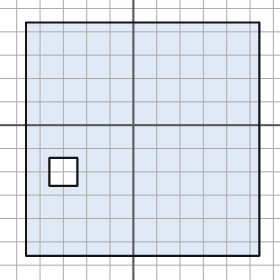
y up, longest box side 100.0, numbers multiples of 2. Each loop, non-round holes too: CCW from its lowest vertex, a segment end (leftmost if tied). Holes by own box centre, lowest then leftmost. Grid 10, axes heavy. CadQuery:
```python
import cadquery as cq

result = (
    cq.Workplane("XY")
    .moveTo(-46.0, -56.0)
    .lineTo(54.0, -56.0)
    .lineTo(54.0, 44.0)
    .lineTo(-46.0, 44.0)
    .close()
    .moveTo(-36.0, -26.0)
    .lineTo(-24.0, -26.0)
    .lineTo(-24.0, -14.0)
    .lineTo(-36.0, -14.0)
    .close()
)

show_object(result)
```